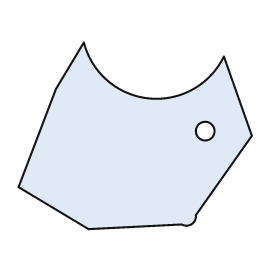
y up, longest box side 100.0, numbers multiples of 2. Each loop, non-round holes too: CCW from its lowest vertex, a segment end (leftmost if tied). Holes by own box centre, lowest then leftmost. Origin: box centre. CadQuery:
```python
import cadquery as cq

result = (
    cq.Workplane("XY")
    .moveTo(-20.0, -40.0)
    .lineTo(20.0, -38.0)
    .threePointArc((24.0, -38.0), (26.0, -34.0))
    .lineTo(50.0, 0.0)
    .lineTo(38.0, 34.0)
    .threePointArc((6.0, 16.0), (-22.0, 40.0))
    .lineTo(-34.0, 20.0)
    .lineTo(-50.0, -22.0)
    .close()
    .moveTo(30.0, 2.0)
    .circle(4.0)
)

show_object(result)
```